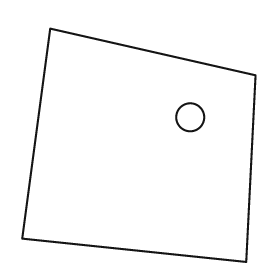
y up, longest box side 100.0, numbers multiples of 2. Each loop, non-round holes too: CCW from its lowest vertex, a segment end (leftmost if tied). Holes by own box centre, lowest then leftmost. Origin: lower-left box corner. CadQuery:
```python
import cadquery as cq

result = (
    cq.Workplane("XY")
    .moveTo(96.0, 0.0)
    .lineTo(100.0, 80.0)
    .lineTo(12.0, 100.0)
    .lineTo(0.0, 10.0)
    .close()
    .moveTo(72.0, 62.0)
    .circle(6.0)
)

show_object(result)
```